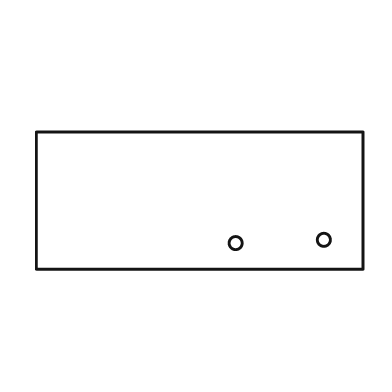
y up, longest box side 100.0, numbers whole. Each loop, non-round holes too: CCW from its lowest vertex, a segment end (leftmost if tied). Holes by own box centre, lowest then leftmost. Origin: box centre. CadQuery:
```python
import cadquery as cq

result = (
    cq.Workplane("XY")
    .moveTo(-50.0, -21.0)
    .lineTo(50.0, -21.0)
    .lineTo(50.0, 21.0)
    .lineTo(-50.0, 21.0)
    .close()
    .moveTo(11.0, -13.0)
    .circle(2.0)
    .moveTo(38.0, -12.0)
    .circle(2.0)
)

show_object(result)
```